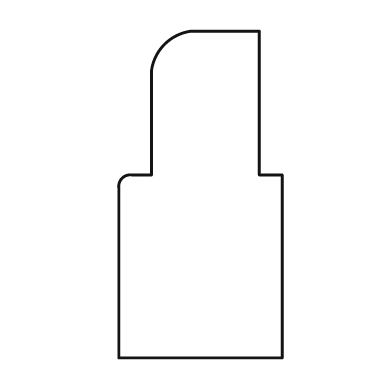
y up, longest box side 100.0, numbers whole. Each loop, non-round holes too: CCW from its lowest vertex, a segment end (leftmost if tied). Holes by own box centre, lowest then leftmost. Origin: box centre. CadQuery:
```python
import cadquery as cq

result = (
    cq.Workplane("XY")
    .moveTo(-25.0, -50.0)
    .lineTo(25.0, -50.0)
    .lineTo(25.0, 6.0)
    .lineTo(18.0, 6.0)
    .lineTo(18.0, 50.0)
    .lineTo(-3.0, 50.0)
    .threePointArc((-11.0, 46.0), (-15.0, 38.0))
    .lineTo(-15.0, 6.0)
    .lineTo(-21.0, 6.0)
    .threePointArc((-24.0, 5.0), (-25.0, 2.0))
    .close()
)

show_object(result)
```